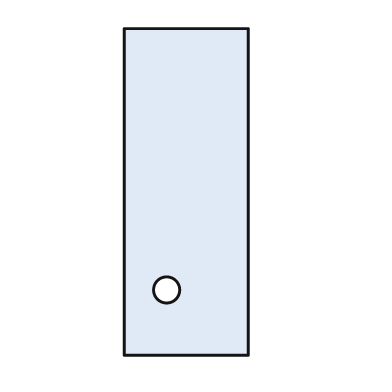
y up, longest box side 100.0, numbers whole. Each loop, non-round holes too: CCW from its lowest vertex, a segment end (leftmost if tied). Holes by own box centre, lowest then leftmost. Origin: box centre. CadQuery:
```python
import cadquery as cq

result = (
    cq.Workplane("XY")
    .moveTo(-19.0, -50.0)
    .lineTo(19.0, -50.0)
    .lineTo(19.0, 50.0)
    .lineTo(-19.0, 50.0)
    .close()
    .moveTo(-6.0, -30.0)
    .circle(4.0)
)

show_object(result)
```